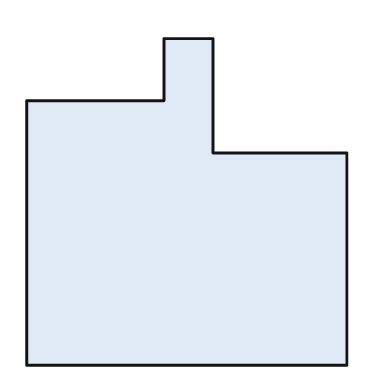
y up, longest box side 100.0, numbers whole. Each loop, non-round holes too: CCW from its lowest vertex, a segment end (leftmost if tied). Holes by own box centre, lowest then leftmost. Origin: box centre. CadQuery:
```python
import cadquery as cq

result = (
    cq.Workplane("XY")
    .moveTo(-49.0, -50.0)
    .lineTo(49.0, -50.0)
    .lineTo(49.0, 15.0)
    .lineTo(8.0, 15.0)
    .lineTo(8.0, 50.0)
    .lineTo(-7.0, 50.0)
    .lineTo(-7.0, 31.0)
    .lineTo(-49.0, 31.0)
    .close()
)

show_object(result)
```